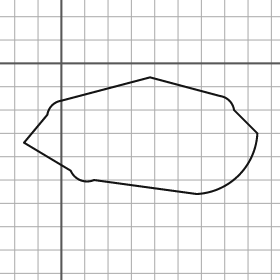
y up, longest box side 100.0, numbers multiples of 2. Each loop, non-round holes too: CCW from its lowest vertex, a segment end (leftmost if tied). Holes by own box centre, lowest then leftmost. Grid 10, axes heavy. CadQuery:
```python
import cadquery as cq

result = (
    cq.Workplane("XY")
    .moveTo(58.0, -56.0)
    .threePointArc((76.0, -48.0), (84.0, -30.0))
    .lineTo(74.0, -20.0)
    .threePointArc((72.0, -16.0), (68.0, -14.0))
    .lineTo(38.0, -6.0)
    .lineTo(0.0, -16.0)
    .threePointArc((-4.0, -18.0), (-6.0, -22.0))
    .lineTo(-16.0, -34.0)
    .lineTo(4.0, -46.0)
    .threePointArc((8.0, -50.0), (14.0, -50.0))
    .close()
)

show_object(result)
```